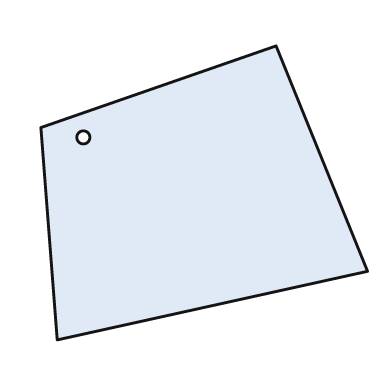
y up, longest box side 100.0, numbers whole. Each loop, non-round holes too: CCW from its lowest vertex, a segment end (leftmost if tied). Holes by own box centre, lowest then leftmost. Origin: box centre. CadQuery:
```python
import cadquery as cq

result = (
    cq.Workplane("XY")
    .moveTo(-45.0, -45.0)
    .lineTo(50.0, -24.0)
    .lineTo(22.0, 45.0)
    .lineTo(-50.0, 20.0)
    .close()
    .moveTo(-37.0, 17.0)
    .circle(2.0)
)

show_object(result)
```